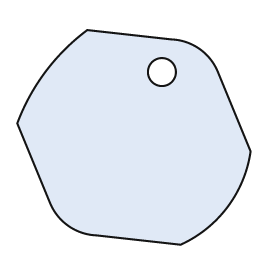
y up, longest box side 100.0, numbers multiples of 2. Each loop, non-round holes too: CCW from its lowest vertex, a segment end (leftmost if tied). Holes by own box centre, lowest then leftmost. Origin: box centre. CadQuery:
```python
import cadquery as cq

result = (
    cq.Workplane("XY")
    .moveTo(20.0, -46.0)
    .threePointArc((40.0, -30.0), (50.0, -6.0))
    .lineTo(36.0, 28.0)
    .threePointArc((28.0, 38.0), (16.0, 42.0))
    .lineTo(-20.0, 46.0)
    .threePointArc((-38.0, 28.0), (-50.0, 6.0))
    .lineTo(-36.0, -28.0)
    .threePointArc((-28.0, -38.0), (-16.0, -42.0))
    .close()
    .moveTo(12.0, 28.0)
    .circle(6.0)
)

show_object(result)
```